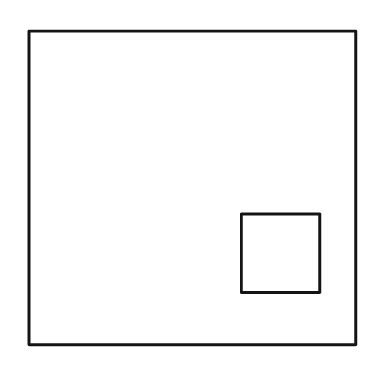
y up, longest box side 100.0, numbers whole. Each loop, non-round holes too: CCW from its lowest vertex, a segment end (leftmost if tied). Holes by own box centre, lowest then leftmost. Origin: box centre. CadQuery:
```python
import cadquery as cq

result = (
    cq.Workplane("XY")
    .moveTo(-50.0, -48.0)
    .lineTo(50.0, -48.0)
    .lineTo(50.0, 48.0)
    .lineTo(-50.0, 48.0)
    .close()
    .moveTo(15.0, -32.0)
    .lineTo(39.0, -32.0)
    .lineTo(39.0, -8.0)
    .lineTo(15.0, -8.0)
    .close()
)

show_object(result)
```